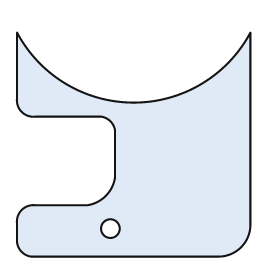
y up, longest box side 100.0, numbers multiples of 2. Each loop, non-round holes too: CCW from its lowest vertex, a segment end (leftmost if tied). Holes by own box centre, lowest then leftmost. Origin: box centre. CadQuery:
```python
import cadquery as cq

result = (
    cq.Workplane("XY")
    .moveTo(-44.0, -48.0)
    .lineTo(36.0, -48.0)
    .threePointArc((46.0, -44.0), (50.0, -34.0))
    .lineTo(50.0, 48.0)
    .threePointArc((0.0, 18.0), (-50.0, 48.0))
    .lineTo(-50.0, 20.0)
    .threePointArc((-48.0, 14.0), (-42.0, 12.0))
    .lineTo(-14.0, 12.0)
    .threePointArc((-10.0, 10.0), (-8.0, 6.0))
    .lineTo(-8.0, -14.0)
    .threePointArc((-12.0, -22.0), (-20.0, -26.0))
    .lineTo(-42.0, -26.0)
    .threePointArc((-48.0, -28.0), (-50.0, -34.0))
    .lineTo(-50.0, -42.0)
    .threePointArc((-48.0, -46.0), (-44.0, -48.0))
    .close()
    .moveTo(-10.0, -36.0)
    .circle(4.0)
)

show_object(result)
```